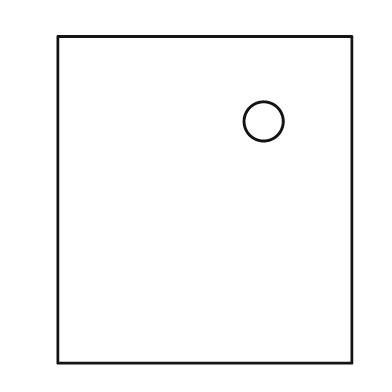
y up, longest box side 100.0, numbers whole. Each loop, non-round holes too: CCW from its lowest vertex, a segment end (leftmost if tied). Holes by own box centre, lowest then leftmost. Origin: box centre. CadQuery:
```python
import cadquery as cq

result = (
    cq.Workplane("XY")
    .moveTo(-45.0, -50.0)
    .lineTo(45.0, -50.0)
    .lineTo(45.0, 50.0)
    .lineTo(-45.0, 50.0)
    .close()
    .moveTo(18.0, 24.0)
    .circle(6.0)
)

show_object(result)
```